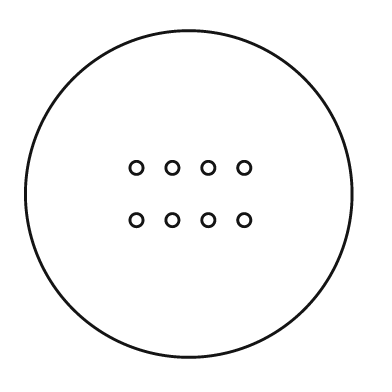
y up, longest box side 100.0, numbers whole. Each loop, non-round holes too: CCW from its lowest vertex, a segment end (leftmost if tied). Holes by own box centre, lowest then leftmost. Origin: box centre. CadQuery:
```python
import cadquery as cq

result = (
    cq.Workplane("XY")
    .moveTo(0.0, 0.0)
    .circle(50.0)
    .moveTo(-16.0, -8.0)
    .circle(2.0)
    .moveTo(-5.0, -8.0)
    .circle(2.0)
    .moveTo(6.0, -8.0)
    .circle(2.0)
    .moveTo(17.0, -8.0)
    .circle(2.0)
    .moveTo(-16.0, 8.0)
    .circle(2.0)
    .moveTo(-5.0, 8.0)
    .circle(2.0)
    .moveTo(6.0, 8.0)
    .circle(2.0)
    .moveTo(17.0, 8.0)
    .circle(2.0)
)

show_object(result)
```